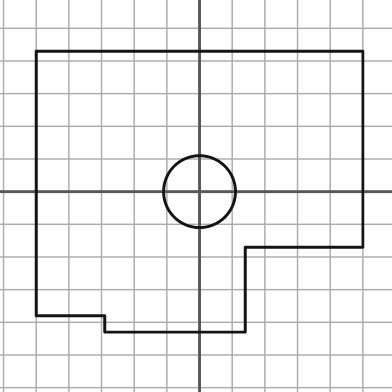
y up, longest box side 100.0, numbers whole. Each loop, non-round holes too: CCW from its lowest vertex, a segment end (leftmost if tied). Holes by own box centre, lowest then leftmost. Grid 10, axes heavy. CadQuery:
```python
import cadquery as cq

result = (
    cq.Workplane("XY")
    .moveTo(-29.0, -43.0)
    .lineTo(14.0, -43.0)
    .lineTo(14.0, -17.0)
    .lineTo(50.0, -17.0)
    .lineTo(50.0, 43.0)
    .lineTo(-50.0, 43.0)
    .lineTo(-50.0, -38.0)
    .lineTo(-29.0, -38.0)
    .close()
    .moveTo(0.0, 0.0)
    .circle(11.0)
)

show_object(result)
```